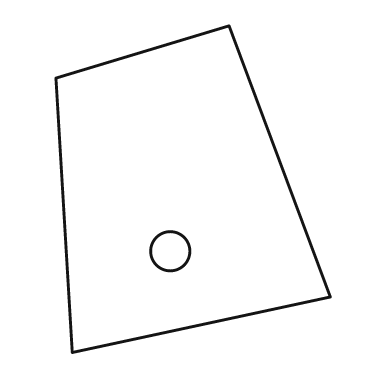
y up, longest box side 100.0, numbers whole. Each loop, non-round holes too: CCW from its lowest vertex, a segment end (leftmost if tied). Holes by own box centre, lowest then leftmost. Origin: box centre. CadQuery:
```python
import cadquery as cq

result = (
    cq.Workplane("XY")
    .moveTo(-37.0, -50.0)
    .lineTo(42.0, -33.0)
    .lineTo(11.0, 50.0)
    .lineTo(-42.0, 34.0)
    .close()
    .moveTo(-7.0, -19.0)
    .circle(6.0)
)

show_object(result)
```